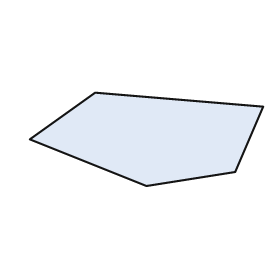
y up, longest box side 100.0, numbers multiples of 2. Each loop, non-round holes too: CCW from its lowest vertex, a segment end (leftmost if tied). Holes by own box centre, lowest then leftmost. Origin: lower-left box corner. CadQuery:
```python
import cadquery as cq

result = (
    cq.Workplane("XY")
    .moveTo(50.0, 0.0)
    .lineTo(88.0, 6.0)
    .lineTo(100.0, 34.0)
    .lineTo(28.0, 40.0)
    .lineTo(0.0, 20.0)
    .close()
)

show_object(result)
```